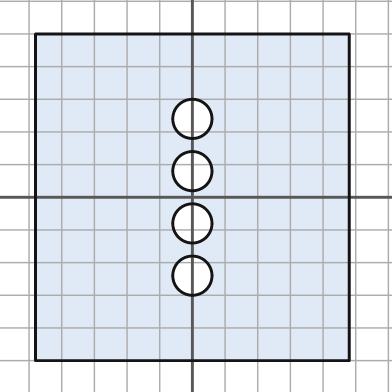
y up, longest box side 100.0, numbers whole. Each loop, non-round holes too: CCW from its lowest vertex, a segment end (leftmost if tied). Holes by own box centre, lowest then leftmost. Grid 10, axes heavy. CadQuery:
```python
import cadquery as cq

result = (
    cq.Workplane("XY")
    .moveTo(-48.0, -50.0)
    .lineTo(48.0, -50.0)
    .lineTo(48.0, 50.0)
    .lineTo(-48.0, 50.0)
    .close()
    .moveTo(0.0, -24.0)
    .circle(6.0)
    .moveTo(0.0, -8.0)
    .circle(6.0)
    .moveTo(0.0, 8.0)
    .circle(6.0)
    .moveTo(0.0, 24.0)
    .circle(6.0)
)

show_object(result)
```